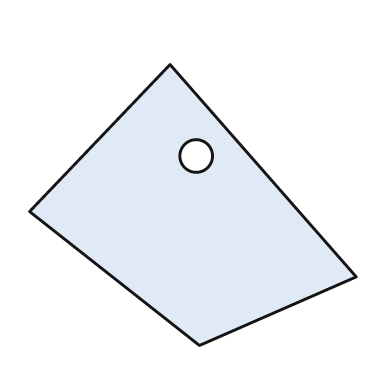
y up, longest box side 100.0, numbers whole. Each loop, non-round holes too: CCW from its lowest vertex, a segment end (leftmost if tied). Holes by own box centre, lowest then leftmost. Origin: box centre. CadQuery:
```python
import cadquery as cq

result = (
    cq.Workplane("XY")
    .moveTo(2.0, -43.0)
    .lineTo(50.0, -22.0)
    .lineTo(-7.0, 43.0)
    .lineTo(-50.0, -2.0)
    .close()
    .moveTo(1.0, 15.0)
    .circle(5.0)
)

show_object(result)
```